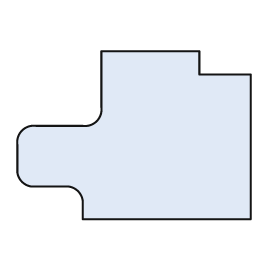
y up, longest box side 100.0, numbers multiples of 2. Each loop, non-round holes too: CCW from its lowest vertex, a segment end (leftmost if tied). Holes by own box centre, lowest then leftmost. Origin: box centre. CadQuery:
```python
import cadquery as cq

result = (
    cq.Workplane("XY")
    .moveTo(-22.0, -36.0)
    .lineTo(50.0, -36.0)
    .lineTo(50.0, 26.0)
    .lineTo(28.0, 26.0)
    .lineTo(28.0, 36.0)
    .lineTo(-14.0, 36.0)
    .lineTo(-14.0, 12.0)
    .threePointArc((-16.0, 6.0), (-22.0, 4.0))
    .lineTo(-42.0, 4.0)
    .threePointArc((-48.0, 2.0), (-50.0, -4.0))
    .lineTo(-50.0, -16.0)
    .threePointArc((-48.0, -20.0), (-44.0, -22.0))
    .lineTo(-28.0, -22.0)
    .threePointArc((-24.0, -24.0), (-22.0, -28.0))
    .close()
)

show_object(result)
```